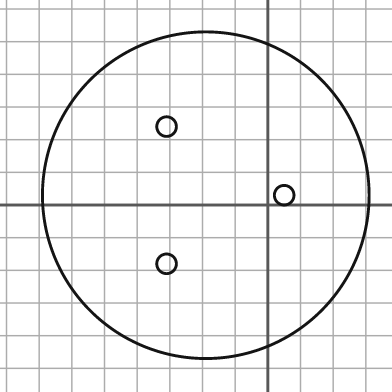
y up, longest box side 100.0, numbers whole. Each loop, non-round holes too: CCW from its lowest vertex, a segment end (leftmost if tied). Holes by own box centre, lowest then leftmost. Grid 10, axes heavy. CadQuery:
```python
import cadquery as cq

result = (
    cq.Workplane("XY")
    .moveTo(-19.0, 3.0)
    .circle(50.0)
    .moveTo(-31.0, -18.0)
    .circle(3.0)
    .moveTo(5.0, 3.0)
    .circle(3.0)
    .moveTo(-31.0, 24.0)
    .circle(3.0)
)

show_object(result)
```